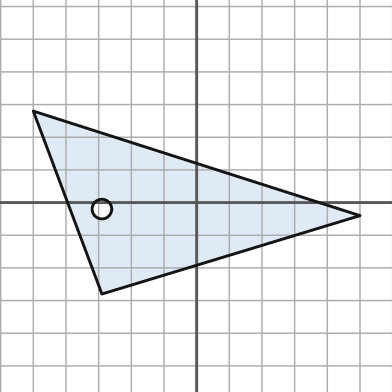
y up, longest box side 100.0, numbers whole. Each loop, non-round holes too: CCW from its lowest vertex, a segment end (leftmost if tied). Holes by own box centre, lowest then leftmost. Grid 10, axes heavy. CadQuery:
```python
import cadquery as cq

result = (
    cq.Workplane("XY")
    .moveTo(-29.0, -28.0)
    .lineTo(50.0, -4.0)
    .lineTo(-50.0, 28.0)
    .close()
    .moveTo(-29.0, -2.0)
    .circle(3.0)
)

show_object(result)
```